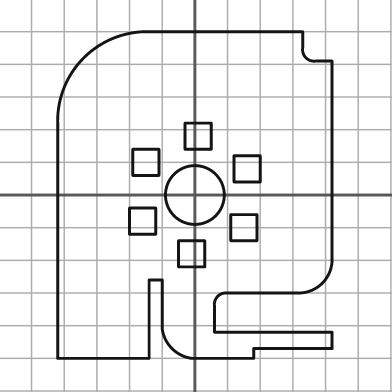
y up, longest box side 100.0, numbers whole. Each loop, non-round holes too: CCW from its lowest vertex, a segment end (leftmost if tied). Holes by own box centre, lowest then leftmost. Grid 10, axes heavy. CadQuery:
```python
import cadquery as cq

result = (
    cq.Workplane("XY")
    .moveTo(-42.0, -50.0)
    .lineTo(-14.0, -50.0)
    .lineTo(-14.0, -26.0)
    .lineTo(-10.0, -26.0)
    .lineTo(-10.0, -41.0)
    .threePointArc((-7.0, -47.0), (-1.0, -50.0))
    .lineTo(18.0, -50.0)
    .lineTo(18.0, -47.0)
    .lineTo(42.0, -47.0)
    .lineTo(42.0, -42.0)
    .lineTo(6.0, -42.0)
    .lineTo(6.0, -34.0)
    .threePointArc((7.0, -31.0), (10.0, -30.0))
    .lineTo(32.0, -30.0)
    .threePointArc((39.0, -27.0), (42.0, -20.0))
    .lineTo(42.0, 41.0)
    .lineTo(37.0, 41.0)
    .threePointArc((34.0, 42.0), (33.0, 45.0))
    .lineTo(33.0, 50.0)
    .lineTo(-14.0, 50.0)
    .threePointArc((-34.0, 42.0), (-42.0, 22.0))
    .close()
    .moveTo(-5.0, -22.0)
    .lineTo(3.0, -22.0)
    .lineTo(3.0, -14.0)
    .lineTo(-5.0, -14.0)
    .close()
    .moveTo(11.0, -14.0)
    .lineTo(19.0, -14.0)
    .lineTo(19.0, -6.0)
    .lineTo(11.0, -6.0)
    .close()
    .moveTo(-20.0, -12.0)
    .lineTo(-12.0, -12.0)
    .lineTo(-12.0, -4.0)
    .lineTo(-20.0, -4.0)
    .close()
    .moveTo(0.0, 0.0)
    .circle(9.0)
    .moveTo(12.0, 4.0)
    .lineTo(20.0, 4.0)
    .lineTo(20.0, 12.0)
    .lineTo(12.0, 12.0)
    .close()
    .moveTo(-19.0, 6.0)
    .lineTo(-11.0, 6.0)
    .lineTo(-11.0, 14.0)
    .lineTo(-19.0, 14.0)
    .close()
    .moveTo(-3.0, 14.0)
    .lineTo(5.0, 14.0)
    .lineTo(5.0, 22.0)
    .lineTo(-3.0, 22.0)
    .close()
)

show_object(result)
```